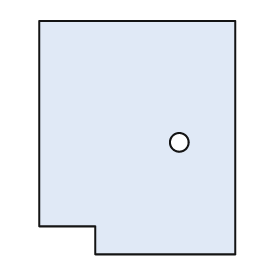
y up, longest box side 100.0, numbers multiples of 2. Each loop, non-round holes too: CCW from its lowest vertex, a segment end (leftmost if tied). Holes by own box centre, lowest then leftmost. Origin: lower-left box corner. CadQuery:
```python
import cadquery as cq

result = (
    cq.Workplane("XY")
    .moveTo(24.0, 0.0)
    .lineTo(84.0, 0.0)
    .lineTo(84.0, 100.0)
    .lineTo(0.0, 100.0)
    .lineTo(0.0, 12.0)
    .lineTo(24.0, 12.0)
    .close()
    .moveTo(60.0, 48.0)
    .circle(4.0)
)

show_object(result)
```